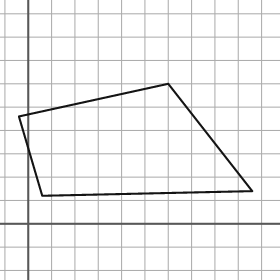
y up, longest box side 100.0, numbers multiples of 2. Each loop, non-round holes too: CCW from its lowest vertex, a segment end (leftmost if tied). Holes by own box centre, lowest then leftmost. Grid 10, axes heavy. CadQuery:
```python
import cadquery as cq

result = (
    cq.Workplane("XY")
    .moveTo(6.0, 12.0)
    .lineTo(96.0, 14.0)
    .lineTo(60.0, 60.0)
    .lineTo(-4.0, 46.0)
    .close()
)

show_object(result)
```